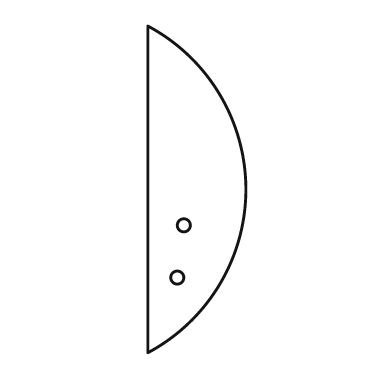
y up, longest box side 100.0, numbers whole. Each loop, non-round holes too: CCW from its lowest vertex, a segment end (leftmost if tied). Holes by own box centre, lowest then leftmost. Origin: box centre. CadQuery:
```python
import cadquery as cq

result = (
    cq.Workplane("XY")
    .moveTo(-15.0, -50.0)
    .threePointArc((15.0, 0.0), (-15.0, 50.0))
    .close()
    .moveTo(-6.0, -27.0)
    .circle(2.0)
    .moveTo(-4.0, -11.0)
    .circle(2.0)
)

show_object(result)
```